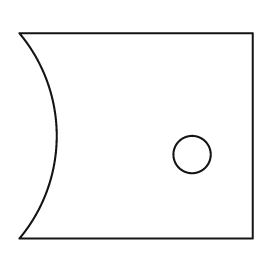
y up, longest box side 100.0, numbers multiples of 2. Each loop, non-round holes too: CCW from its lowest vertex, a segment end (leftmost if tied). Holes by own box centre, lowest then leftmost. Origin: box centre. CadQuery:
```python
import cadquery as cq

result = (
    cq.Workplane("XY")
    .moveTo(-50.0, -44.0)
    .lineTo(50.0, -44.0)
    .lineTo(50.0, 44.0)
    .lineTo(-50.0, 44.0)
    .threePointArc((-34.0, 0.0), (-50.0, -44.0))
    .close()
    .moveTo(24.0, -8.0)
    .circle(8.0)
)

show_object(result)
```